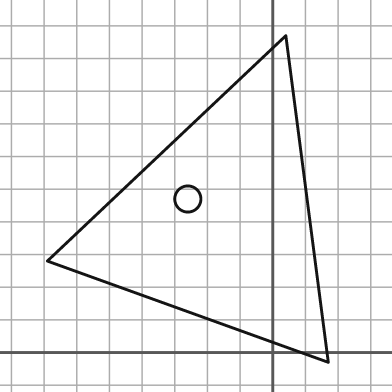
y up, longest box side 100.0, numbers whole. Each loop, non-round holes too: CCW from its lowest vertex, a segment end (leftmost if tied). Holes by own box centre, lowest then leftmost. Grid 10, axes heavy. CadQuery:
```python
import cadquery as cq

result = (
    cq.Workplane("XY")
    .moveTo(17.0, -3.0)
    .lineTo(4.0, 97.0)
    .lineTo(-69.0, 28.0)
    .close()
    .moveTo(-26.0, 47.0)
    .circle(4.0)
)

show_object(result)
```